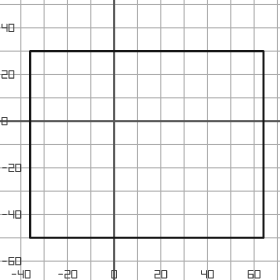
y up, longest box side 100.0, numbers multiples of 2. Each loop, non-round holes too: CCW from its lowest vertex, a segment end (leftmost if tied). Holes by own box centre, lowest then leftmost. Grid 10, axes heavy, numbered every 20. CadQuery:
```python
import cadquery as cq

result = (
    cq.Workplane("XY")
    .moveTo(-36.0, -50.0)
    .lineTo(64.0, -50.0)
    .lineTo(64.0, 30.0)
    .lineTo(-36.0, 30.0)
    .close()
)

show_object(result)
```